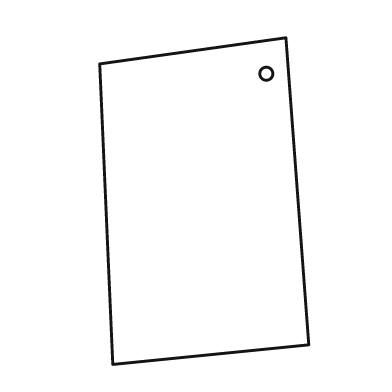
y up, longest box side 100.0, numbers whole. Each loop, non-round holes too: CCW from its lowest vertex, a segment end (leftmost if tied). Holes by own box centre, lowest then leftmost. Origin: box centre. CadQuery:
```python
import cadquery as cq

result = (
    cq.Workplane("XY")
    .moveTo(-28.0, -50.0)
    .lineTo(32.0, -44.0)
    .lineTo(25.0, 50.0)
    .lineTo(-32.0, 42.0)
    .close()
    .moveTo(19.0, 39.0)
    .circle(2.0)
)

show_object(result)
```